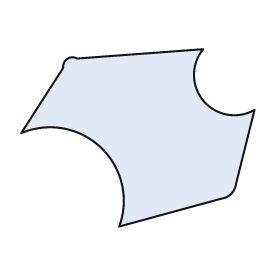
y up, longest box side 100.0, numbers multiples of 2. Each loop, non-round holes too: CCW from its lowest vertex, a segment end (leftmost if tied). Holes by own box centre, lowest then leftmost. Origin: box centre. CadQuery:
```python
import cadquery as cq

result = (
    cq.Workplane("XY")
    .moveTo(-8.0, -38.0)
    .lineTo(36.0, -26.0)
    .threePointArc((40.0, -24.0), (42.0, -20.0))
    .lineTo(50.0, 12.0)
    .threePointArc((28.0, 16.0), (28.0, 38.0))
    .lineTo(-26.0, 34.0)
    .threePointArc((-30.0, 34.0), (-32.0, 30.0))
    .lineTo(-50.0, 2.0)
    .threePointArc((-16.0, -4.0), (-8.0, -38.0))
    .close()
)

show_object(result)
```